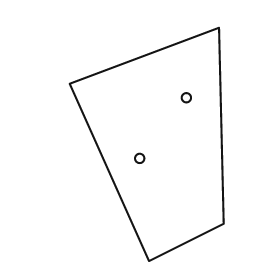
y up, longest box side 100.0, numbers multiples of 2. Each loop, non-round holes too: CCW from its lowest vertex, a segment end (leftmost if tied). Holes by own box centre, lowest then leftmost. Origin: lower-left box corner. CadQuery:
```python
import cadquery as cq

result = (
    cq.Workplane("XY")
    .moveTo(34.0, 0.0)
    .lineTo(66.0, 16.0)
    .lineTo(64.0, 100.0)
    .lineTo(0.0, 76.0)
    .close()
    .moveTo(30.0, 44.0)
    .circle(2.0)
    .moveTo(50.0, 70.0)
    .circle(2.0)
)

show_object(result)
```